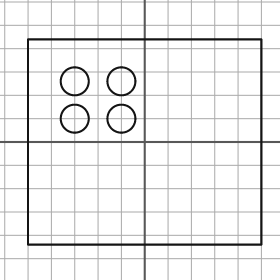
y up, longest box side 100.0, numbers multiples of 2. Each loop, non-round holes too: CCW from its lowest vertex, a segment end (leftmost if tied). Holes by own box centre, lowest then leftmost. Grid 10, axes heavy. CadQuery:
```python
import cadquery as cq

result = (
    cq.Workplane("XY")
    .moveTo(-50.0, -44.0)
    .lineTo(50.0, -44.0)
    .lineTo(50.0, 44.0)
    .lineTo(-50.0, 44.0)
    .close()
    .moveTo(-30.0, 10.0)
    .circle(6.0)
    .moveTo(-10.0, 10.0)
    .circle(6.0)
    .moveTo(-30.0, 26.0)
    .circle(6.0)
    .moveTo(-10.0, 26.0)
    .circle(6.0)
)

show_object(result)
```